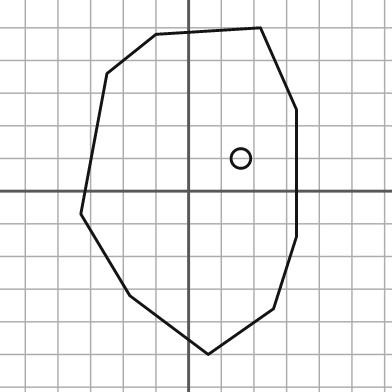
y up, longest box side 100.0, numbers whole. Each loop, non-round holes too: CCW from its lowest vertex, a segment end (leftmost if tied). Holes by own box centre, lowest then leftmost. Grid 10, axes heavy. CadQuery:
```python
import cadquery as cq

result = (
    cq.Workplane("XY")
    .moveTo(6.0, -50.0)
    .lineTo(26.0, -36.0)
    .lineTo(33.0, -14.0)
    .lineTo(33.0, 25.0)
    .lineTo(22.0, 50.0)
    .lineTo(-10.0, 48.0)
    .lineTo(-25.0, 36.0)
    .lineTo(-33.0, -7.0)
    .lineTo(-18.0, -32.0)
    .close()
    .moveTo(16.0, 10.0)
    .circle(3.0)
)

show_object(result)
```